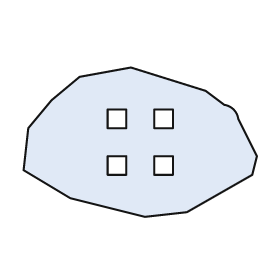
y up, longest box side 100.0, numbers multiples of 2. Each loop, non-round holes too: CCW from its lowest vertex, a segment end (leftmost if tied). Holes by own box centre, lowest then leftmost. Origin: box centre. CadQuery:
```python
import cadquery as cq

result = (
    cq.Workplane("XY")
    .moveTo(2.0, -32.0)
    .lineTo(20.0, -30.0)
    .lineTo(48.0, -14.0)
    .lineTo(50.0, -6.0)
    .lineTo(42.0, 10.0)
    .threePointArc((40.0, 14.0), (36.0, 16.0))
    .lineTo(28.0, 22.0)
    .lineTo(-4.0, 32.0)
    .lineTo(-26.0, 28.0)
    .lineTo(-38.0, 18.0)
    .lineTo(-48.0, 6.0)
    .lineTo(-50.0, -12.0)
    .lineTo(-30.0, -24.0)
    .close()
    .moveTo(-14.0, -14.0)
    .lineTo(-6.0, -14.0)
    .lineTo(-6.0, -6.0)
    .lineTo(-14.0, -6.0)
    .close()
    .moveTo(6.0, -14.0)
    .lineTo(14.0, -14.0)
    .lineTo(14.0, -6.0)
    .lineTo(6.0, -6.0)
    .close()
    .moveTo(-14.0, 6.0)
    .lineTo(-6.0, 6.0)
    .lineTo(-6.0, 14.0)
    .lineTo(-14.0, 14.0)
    .close()
    .moveTo(6.0, 6.0)
    .lineTo(14.0, 6.0)
    .lineTo(14.0, 14.0)
    .lineTo(6.0, 14.0)
    .close()
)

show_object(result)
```